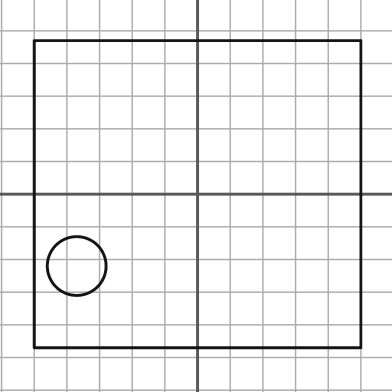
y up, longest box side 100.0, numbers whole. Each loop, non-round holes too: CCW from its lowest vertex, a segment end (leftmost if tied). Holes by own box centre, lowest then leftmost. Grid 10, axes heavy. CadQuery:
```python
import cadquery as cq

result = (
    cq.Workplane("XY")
    .moveTo(-50.0, -47.0)
    .lineTo(50.0, -47.0)
    .lineTo(50.0, 47.0)
    .lineTo(-50.0, 47.0)
    .close()
    .moveTo(-37.0, -22.0)
    .circle(9.0)
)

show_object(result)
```